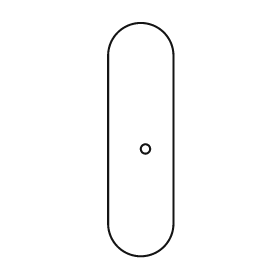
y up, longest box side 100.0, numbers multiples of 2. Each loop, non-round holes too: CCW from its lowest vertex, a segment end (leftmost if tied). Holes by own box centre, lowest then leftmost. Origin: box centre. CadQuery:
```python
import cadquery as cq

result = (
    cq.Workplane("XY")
    .moveTo(-14.0, -36.0)
    .threePointArc((0.0, -50.0), (14.0, -36.0))
    .lineTo(14.0, 36.0)
    .threePointArc((0.0, 50.0), (-14.0, 36.0))
    .close()
    .moveTo(2.0, -4.0)
    .circle(2.0)
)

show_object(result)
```